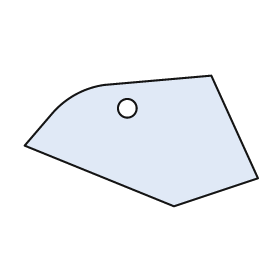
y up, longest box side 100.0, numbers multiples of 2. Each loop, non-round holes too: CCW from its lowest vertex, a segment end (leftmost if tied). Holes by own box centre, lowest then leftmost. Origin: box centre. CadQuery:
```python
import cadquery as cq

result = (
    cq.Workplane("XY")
    .moveTo(14.0, -28.0)
    .lineTo(50.0, -16.0)
    .lineTo(30.0, 28.0)
    .lineTo(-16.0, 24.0)
    .threePointArc((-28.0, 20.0), (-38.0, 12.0))
    .lineTo(-50.0, -2.0)
    .close()
    .moveTo(-6.0, 14.0)
    .circle(4.0)
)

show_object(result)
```